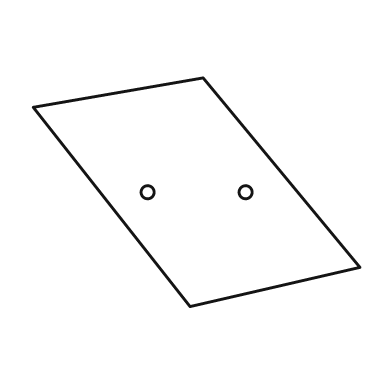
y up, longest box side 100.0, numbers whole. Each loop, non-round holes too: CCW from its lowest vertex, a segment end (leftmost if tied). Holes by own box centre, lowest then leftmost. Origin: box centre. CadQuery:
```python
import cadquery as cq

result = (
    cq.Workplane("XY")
    .moveTo(-2.0, -35.0)
    .lineTo(50.0, -23.0)
    .lineTo(2.0, 35.0)
    .lineTo(-50.0, 26.0)
    .close()
    .moveTo(-15.0, 0.0)
    .circle(2.0)
    .moveTo(15.0, 0.0)
    .circle(2.0)
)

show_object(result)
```